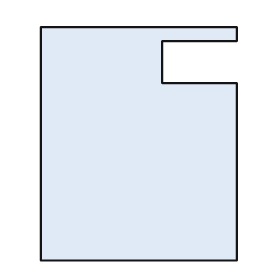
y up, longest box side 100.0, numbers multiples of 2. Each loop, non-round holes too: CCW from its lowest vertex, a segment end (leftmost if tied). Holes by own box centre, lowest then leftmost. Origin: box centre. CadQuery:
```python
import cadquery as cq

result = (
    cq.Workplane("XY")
    .moveTo(-42.0, -50.0)
    .lineTo(42.0, -50.0)
    .lineTo(42.0, 26.0)
    .lineTo(10.0, 26.0)
    .lineTo(10.0, 44.0)
    .lineTo(42.0, 44.0)
    .lineTo(42.0, 50.0)
    .lineTo(-42.0, 50.0)
    .close()
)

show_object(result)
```